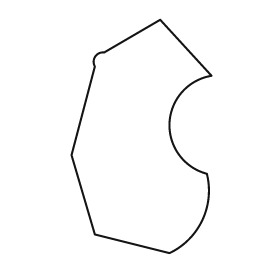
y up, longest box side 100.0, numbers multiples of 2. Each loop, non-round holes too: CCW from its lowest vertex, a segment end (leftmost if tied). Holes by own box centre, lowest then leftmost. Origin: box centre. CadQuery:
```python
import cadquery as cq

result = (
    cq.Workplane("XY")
    .moveTo(12.0, -50.0)
    .threePointArc((26.0, -36.0), (28.0, -16.0))
    .threePointArc((12.0, 6.0), (30.0, 26.0))
    .lineTo(8.0, 50.0)
    .lineTo(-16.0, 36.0)
    .threePointArc((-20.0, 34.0), (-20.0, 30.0))
    .lineTo(-30.0, -8.0)
    .lineTo(-20.0, -42.0)
    .close()
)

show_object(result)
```